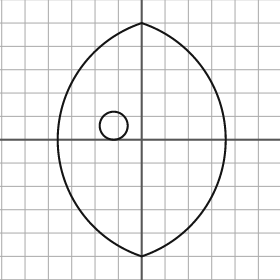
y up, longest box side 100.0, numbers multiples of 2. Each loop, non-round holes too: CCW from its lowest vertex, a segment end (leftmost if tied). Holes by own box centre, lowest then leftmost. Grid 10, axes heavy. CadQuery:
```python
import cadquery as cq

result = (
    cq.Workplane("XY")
    .moveTo(0.0, -50.0)
    .threePointArc((36.0, 0.0), (0.0, 50.0))
    .threePointArc((-36.0, 0.0), (0.0, -50.0))
    .close()
    .moveTo(-12.0, 6.0)
    .circle(6.0)
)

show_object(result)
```